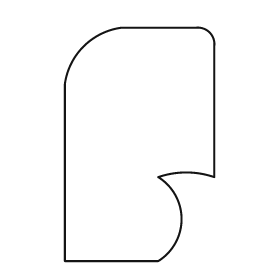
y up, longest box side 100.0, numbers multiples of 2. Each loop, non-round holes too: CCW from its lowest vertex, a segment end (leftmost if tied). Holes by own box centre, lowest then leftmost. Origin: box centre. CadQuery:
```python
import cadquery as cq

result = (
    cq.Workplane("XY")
    .moveTo(-32.0, -50.0)
    .lineTo(8.0, -50.0)
    .threePointArc((18.0, -32.0), (8.0, -14.0))
    .threePointArc((20.0, -12.0), (32.0, -14.0))
    .lineTo(32.0, 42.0)
    .threePointArc((30.0, 48.0), (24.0, 50.0))
    .lineTo(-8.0, 50.0)
    .threePointArc((-24.0, 42.0), (-32.0, 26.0))
    .close()
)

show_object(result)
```